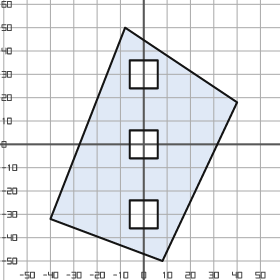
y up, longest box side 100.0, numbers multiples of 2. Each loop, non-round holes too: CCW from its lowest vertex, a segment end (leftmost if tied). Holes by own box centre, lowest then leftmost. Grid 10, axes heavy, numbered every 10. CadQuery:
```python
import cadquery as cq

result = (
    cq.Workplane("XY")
    .moveTo(8.0, -50.0)
    .lineTo(40.0, 18.0)
    .lineTo(-8.0, 50.0)
    .lineTo(-40.0, -32.0)
    .close()
    .moveTo(-6.0, -36.0)
    .lineTo(6.0, -36.0)
    .lineTo(6.0, -24.0)
    .lineTo(-6.0, -24.0)
    .close()
    .moveTo(-6.0, -6.0)
    .lineTo(6.0, -6.0)
    .lineTo(6.0, 6.0)
    .lineTo(-6.0, 6.0)
    .close()
    .moveTo(-6.0, 24.0)
    .lineTo(6.0, 24.0)
    .lineTo(6.0, 36.0)
    .lineTo(-6.0, 36.0)
    .close()
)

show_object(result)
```